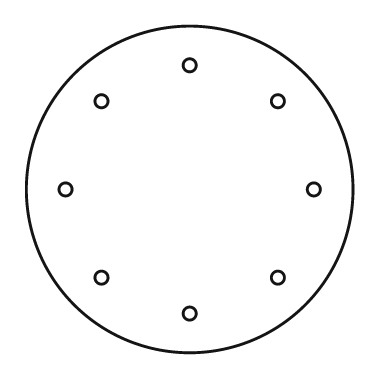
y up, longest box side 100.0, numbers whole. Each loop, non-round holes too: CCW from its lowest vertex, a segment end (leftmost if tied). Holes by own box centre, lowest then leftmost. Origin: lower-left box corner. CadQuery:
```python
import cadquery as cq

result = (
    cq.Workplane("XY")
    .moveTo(50.0, 50.0)
    .circle(50.0)
    .moveTo(50.0, 12.0)
    .circle(2.0)
    .moveTo(23.0, 23.0)
    .circle(2.0)
    .moveTo(77.0, 23.0)
    .circle(2.0)
    .moveTo(12.0, 50.0)
    .circle(2.0)
    .moveTo(88.0, 50.0)
    .circle(2.0)
    .moveTo(23.0, 77.0)
    .circle(2.0)
    .moveTo(77.0, 77.0)
    .circle(2.0)
    .moveTo(50.0, 88.0)
    .circle(2.0)
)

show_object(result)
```